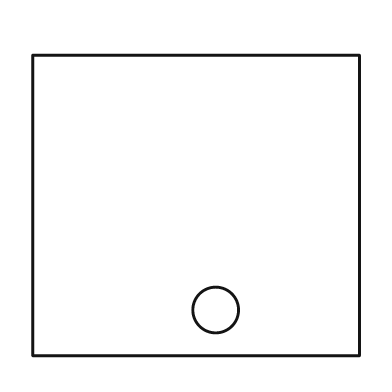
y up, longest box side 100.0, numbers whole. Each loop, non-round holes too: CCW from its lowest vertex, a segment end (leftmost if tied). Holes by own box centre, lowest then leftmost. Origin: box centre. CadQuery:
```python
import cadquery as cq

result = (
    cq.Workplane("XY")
    .moveTo(-50.0, -46.0)
    .lineTo(50.0, -46.0)
    .lineTo(50.0, 46.0)
    .lineTo(-50.0, 46.0)
    .close()
    .moveTo(6.0, -32.0)
    .circle(7.0)
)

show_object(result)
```